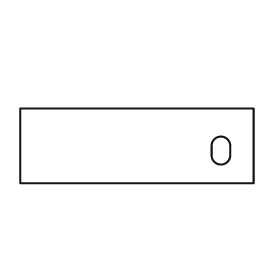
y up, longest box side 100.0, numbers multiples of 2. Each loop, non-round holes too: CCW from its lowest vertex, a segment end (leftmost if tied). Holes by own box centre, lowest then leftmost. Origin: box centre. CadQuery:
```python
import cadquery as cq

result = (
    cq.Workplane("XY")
    .moveTo(-50.0, -16.0)
    .lineTo(50.0, -16.0)
    .lineTo(50.0, 16.0)
    .lineTo(-50.0, 16.0)
    .close()
    .moveTo(32.0, -4.0)
    .threePointArc((36.0, -8.0), (40.0, -4.0))
    .lineTo(40.0, 0.0)
    .threePointArc((36.0, 4.0), (32.0, 0.0))
    .close()
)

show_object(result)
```